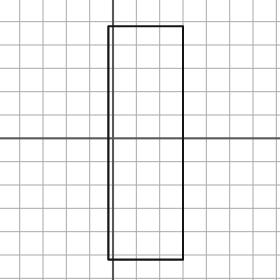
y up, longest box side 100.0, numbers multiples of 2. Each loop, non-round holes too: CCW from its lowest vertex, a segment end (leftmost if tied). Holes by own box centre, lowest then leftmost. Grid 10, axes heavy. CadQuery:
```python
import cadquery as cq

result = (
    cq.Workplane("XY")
    .moveTo(-2.0, -52.0)
    .lineTo(30.0, -52.0)
    .lineTo(30.0, 48.0)
    .lineTo(-2.0, 48.0)
    .close()
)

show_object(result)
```